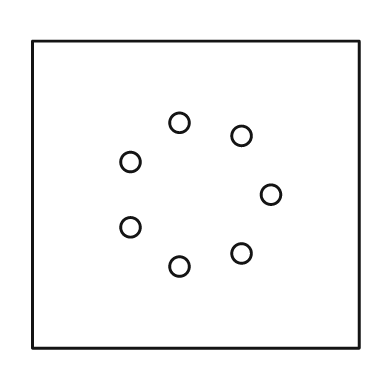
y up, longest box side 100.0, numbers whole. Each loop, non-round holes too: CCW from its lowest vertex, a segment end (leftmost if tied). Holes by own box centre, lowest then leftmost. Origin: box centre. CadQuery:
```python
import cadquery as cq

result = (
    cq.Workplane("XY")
    .moveTo(-50.0, -47.0)
    .lineTo(50.0, -47.0)
    .lineTo(50.0, 47.0)
    .lineTo(-50.0, 47.0)
    .close()
    .moveTo(-5.0, -22.0)
    .circle(3.0)
    .moveTo(14.0, -18.0)
    .circle(3.0)
    .moveTo(-20.0, -10.0)
    .circle(3.0)
    .moveTo(23.0, 0.0)
    .circle(3.0)
    .moveTo(-20.0, 10.0)
    .circle(3.0)
    .moveTo(14.0, 18.0)
    .circle(3.0)
    .moveTo(-5.0, 22.0)
    .circle(3.0)
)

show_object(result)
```